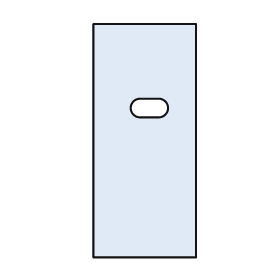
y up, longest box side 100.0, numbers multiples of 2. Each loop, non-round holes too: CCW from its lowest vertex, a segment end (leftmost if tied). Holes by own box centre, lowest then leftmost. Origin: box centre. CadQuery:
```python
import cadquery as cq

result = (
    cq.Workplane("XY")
    .moveTo(-22.0, -50.0)
    .lineTo(22.0, -50.0)
    .lineTo(22.0, 50.0)
    .lineTo(-22.0, 50.0)
    .close()
    .moveTo(-2.0, 10.0)
    .lineTo(6.0, 10.0)
    .threePointArc((10.0, 14.0), (6.0, 18.0))
    .lineTo(-2.0, 18.0)
    .threePointArc((-6.0, 14.0), (-2.0, 10.0))
    .close()
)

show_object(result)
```